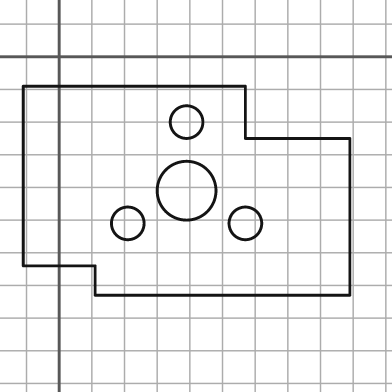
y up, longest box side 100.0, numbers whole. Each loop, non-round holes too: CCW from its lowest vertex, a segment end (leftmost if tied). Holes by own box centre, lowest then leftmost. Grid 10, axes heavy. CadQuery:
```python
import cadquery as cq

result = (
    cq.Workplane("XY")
    .moveTo(11.0, -73.0)
    .lineTo(89.0, -73.0)
    .lineTo(89.0, -25.0)
    .lineTo(57.0, -25.0)
    .lineTo(57.0, -9.0)
    .lineTo(-11.0, -9.0)
    .lineTo(-11.0, -64.0)
    .lineTo(11.0, -64.0)
    .close()
    .moveTo(21.0, -51.0)
    .circle(5.0)
    .moveTo(57.0, -51.0)
    .circle(5.0)
    .moveTo(39.0, -41.0)
    .circle(9.0)
    .moveTo(39.0, -20.0)
    .circle(5.0)
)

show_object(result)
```